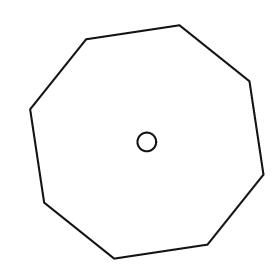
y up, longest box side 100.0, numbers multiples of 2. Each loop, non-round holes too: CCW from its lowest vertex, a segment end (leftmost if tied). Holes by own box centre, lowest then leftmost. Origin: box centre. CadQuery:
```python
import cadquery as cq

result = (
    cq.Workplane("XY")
    .moveTo(-14.0, -50.0)
    .lineTo(26.0, -44.0)
    .lineTo(50.0, -14.0)
    .lineTo(44.0, 26.0)
    .lineTo(14.0, 50.0)
    .lineTo(-26.0, 44.0)
    .lineTo(-50.0, 14.0)
    .lineTo(-44.0, -26.0)
    .close()
    .moveTo(0.0, 0.0)
    .circle(4.0)
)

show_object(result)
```